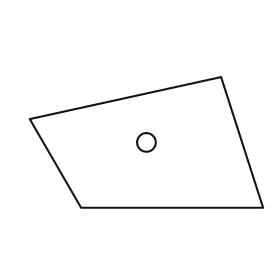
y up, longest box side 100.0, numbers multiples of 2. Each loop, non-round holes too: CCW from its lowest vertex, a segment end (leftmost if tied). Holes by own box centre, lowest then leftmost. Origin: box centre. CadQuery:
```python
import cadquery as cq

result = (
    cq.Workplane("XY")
    .moveTo(-28.0, -28.0)
    .lineTo(50.0, -28.0)
    .lineTo(32.0, 28.0)
    .lineTo(-50.0, 10.0)
    .close()
    .moveTo(0.0, 0.0)
    .circle(4.0)
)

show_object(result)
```